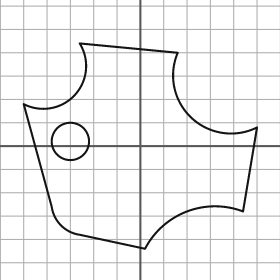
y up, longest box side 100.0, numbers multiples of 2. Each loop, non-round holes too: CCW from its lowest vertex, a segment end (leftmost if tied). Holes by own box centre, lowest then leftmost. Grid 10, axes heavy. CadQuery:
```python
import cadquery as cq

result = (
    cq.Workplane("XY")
    .moveTo(2.0, -44.0)
    .threePointArc((20.0, -28.0), (44.0, -28.0))
    .lineTo(50.0, 8.0)
    .threePointArc((22.0, 12.0), (16.0, 40.0))
    .lineTo(-26.0, 44.0)
    .threePointArc((-28.0, 22.0), (-50.0, 18.0))
    .lineTo(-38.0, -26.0)
    .threePointArc((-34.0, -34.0), (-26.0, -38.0))
    .close()
    .moveTo(-30.0, 2.0)
    .circle(8.0)
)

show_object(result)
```